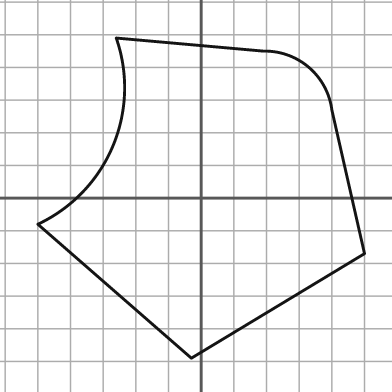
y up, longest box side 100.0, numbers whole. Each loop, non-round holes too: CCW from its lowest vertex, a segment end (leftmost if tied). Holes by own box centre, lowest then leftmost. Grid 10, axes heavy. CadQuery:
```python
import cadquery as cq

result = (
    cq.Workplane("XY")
    .moveTo(-3.0, -49.0)
    .lineTo(50.0, -17.0)
    .lineTo(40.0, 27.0)
    .threePointArc((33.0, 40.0), (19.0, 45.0))
    .lineTo(-26.0, 49.0)
    .threePointArc((-27.0, 16.0), (-50.0, -8.0))
    .close()
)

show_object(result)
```